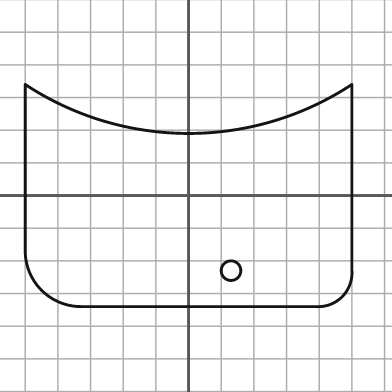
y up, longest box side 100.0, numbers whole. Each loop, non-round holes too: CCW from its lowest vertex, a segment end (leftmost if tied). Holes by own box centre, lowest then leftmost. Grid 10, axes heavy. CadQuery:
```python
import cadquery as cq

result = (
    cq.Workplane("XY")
    .moveTo(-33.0, -34.0)
    .lineTo(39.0, -34.0)
    .threePointArc((47.0, -31.0), (50.0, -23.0))
    .lineTo(50.0, 34.0)
    .threePointArc((0.0, 19.0), (-50.0, 34.0))
    .lineTo(-50.0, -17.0)
    .threePointArc((-45.0, -29.0), (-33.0, -34.0))
    .close()
    .moveTo(13.0, -23.0)
    .circle(3.0)
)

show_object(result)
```